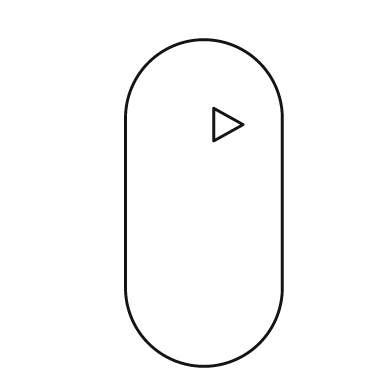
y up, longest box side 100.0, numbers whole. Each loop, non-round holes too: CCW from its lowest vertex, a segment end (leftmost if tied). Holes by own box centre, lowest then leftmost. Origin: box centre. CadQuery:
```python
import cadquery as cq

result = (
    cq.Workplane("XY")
    .moveTo(-24.0, -26.0)
    .threePointArc((0.0, -50.0), (24.0, -26.0))
    .lineTo(24.0, 26.0)
    .threePointArc((0.0, 50.0), (-24.0, 26.0))
    .close()
    .moveTo(3.0, 19.0)
    .lineTo(12.0, 24.0)
    .lineTo(3.0, 29.0)
    .close()
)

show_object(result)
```